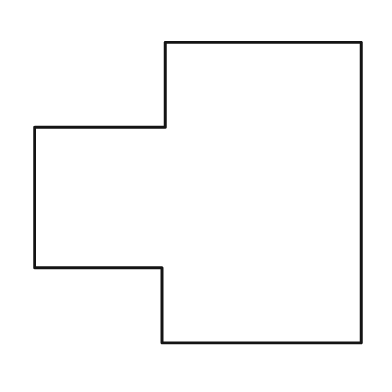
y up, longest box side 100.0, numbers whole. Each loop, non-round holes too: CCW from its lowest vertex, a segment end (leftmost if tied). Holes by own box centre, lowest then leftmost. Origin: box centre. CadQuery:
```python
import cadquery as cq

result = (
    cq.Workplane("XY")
    .moveTo(-11.0, -46.0)
    .lineTo(50.0, -46.0)
    .lineTo(50.0, 46.0)
    .lineTo(-10.0, 46.0)
    .lineTo(-10.0, 20.0)
    .lineTo(-50.0, 20.0)
    .lineTo(-50.0, -23.0)
    .lineTo(-11.0, -23.0)
    .close()
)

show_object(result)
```